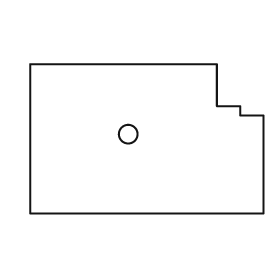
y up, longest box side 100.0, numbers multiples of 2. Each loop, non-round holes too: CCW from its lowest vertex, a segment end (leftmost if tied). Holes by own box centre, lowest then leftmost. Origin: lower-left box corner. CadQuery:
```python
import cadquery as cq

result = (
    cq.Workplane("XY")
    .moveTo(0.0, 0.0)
    .lineTo(100.0, 0.0)
    .lineTo(100.0, 42.0)
    .lineTo(90.0, 42.0)
    .lineTo(90.0, 46.0)
    .lineTo(80.0, 46.0)
    .lineTo(80.0, 64.0)
    .lineTo(0.0, 64.0)
    .close()
    .moveTo(42.0, 34.0)
    .circle(4.0)
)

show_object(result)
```